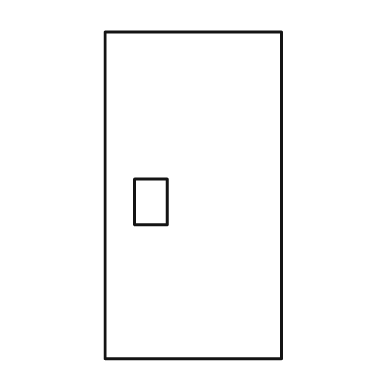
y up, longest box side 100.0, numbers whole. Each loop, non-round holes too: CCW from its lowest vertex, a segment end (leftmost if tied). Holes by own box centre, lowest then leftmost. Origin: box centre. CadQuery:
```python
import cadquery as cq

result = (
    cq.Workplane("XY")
    .moveTo(-27.0, -50.0)
    .lineTo(27.0, -50.0)
    .lineTo(27.0, 50.0)
    .lineTo(-27.0, 50.0)
    .close()
    .moveTo(-18.0, -9.0)
    .lineTo(-8.0, -9.0)
    .lineTo(-8.0, 5.0)
    .lineTo(-18.0, 5.0)
    .close()
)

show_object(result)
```